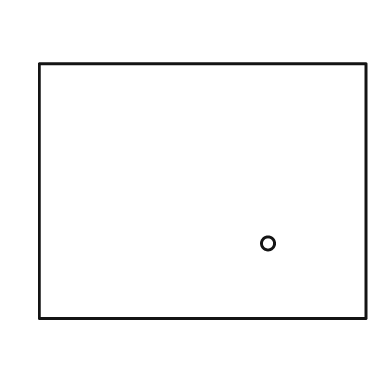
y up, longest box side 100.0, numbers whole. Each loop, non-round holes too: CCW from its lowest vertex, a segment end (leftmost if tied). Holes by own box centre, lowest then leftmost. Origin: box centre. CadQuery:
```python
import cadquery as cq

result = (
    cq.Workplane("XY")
    .moveTo(-50.0, -39.0)
    .lineTo(50.0, -39.0)
    .lineTo(50.0, 39.0)
    .lineTo(-50.0, 39.0)
    .close()
    .moveTo(20.0, -16.0)
    .circle(2.0)
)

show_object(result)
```